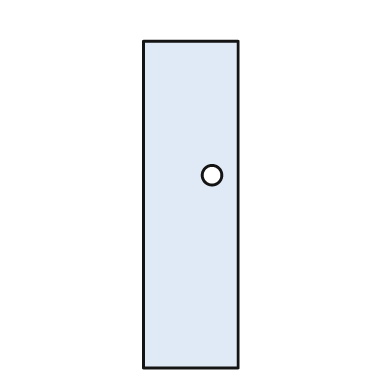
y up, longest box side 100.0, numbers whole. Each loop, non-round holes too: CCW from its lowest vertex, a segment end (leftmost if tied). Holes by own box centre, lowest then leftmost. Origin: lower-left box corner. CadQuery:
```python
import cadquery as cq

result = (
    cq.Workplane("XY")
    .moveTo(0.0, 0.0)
    .lineTo(29.0, 0.0)
    .lineTo(29.0, 100.0)
    .lineTo(0.0, 100.0)
    .close()
    .moveTo(21.0, 59.0)
    .circle(3.0)
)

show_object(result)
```